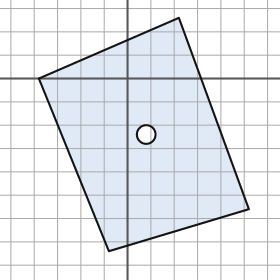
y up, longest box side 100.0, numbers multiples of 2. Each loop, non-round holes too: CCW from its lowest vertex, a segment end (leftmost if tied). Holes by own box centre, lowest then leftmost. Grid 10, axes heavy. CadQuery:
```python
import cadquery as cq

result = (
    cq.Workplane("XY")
    .moveTo(-8.0, -74.0)
    .lineTo(52.0, -56.0)
    .lineTo(22.0, 26.0)
    .lineTo(-38.0, 0.0)
    .close()
    .moveTo(8.0, -24.0)
    .circle(4.0)
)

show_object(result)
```